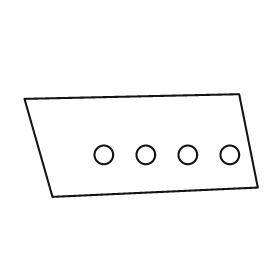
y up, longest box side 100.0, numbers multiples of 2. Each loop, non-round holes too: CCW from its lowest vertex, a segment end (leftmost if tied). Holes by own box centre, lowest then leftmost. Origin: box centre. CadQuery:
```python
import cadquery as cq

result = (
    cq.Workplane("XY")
    .moveTo(-38.0, -22.0)
    .lineTo(50.0, -18.0)
    .lineTo(42.0, 22.0)
    .lineTo(-50.0, 20.0)
    .close()
    .moveTo(-16.0, -4.0)
    .circle(4.0)
    .moveTo(2.0, -4.0)
    .circle(4.0)
    .moveTo(20.0, -4.0)
    .circle(4.0)
    .moveTo(38.0, -4.0)
    .circle(4.0)
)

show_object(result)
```